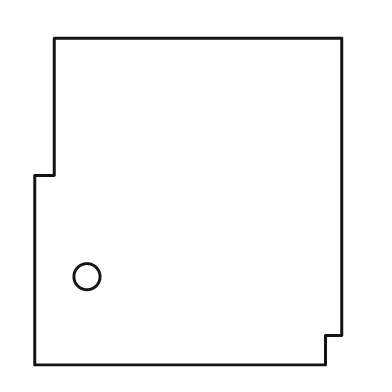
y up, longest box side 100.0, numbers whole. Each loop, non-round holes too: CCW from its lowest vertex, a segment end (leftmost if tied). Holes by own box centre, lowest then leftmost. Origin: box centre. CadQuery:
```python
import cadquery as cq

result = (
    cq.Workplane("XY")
    .moveTo(-47.0, -50.0)
    .lineTo(42.0, -50.0)
    .lineTo(42.0, -41.0)
    .lineTo(47.0, -41.0)
    .lineTo(47.0, 50.0)
    .lineTo(-41.0, 50.0)
    .lineTo(-41.0, 8.0)
    .lineTo(-47.0, 8.0)
    .close()
    .moveTo(-31.0, -23.0)
    .circle(4.0)
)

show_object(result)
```